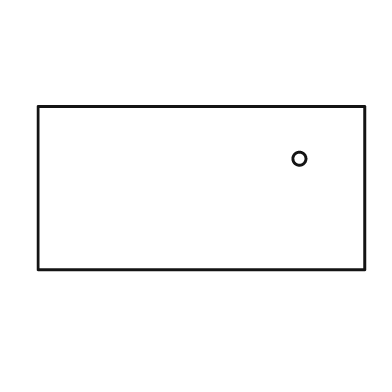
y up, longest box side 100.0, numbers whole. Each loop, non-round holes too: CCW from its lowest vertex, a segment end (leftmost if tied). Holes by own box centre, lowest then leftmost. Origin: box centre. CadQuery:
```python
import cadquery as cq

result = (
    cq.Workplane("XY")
    .moveTo(-50.0, -25.0)
    .lineTo(50.0, -25.0)
    .lineTo(50.0, 25.0)
    .lineTo(-50.0, 25.0)
    .close()
    .moveTo(30.0, 9.0)
    .circle(2.0)
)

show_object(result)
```